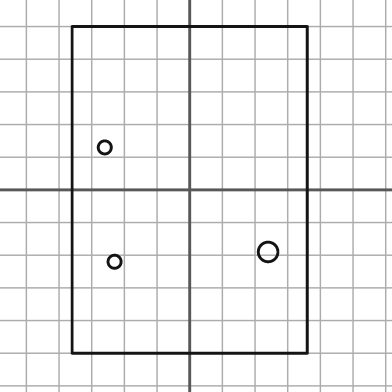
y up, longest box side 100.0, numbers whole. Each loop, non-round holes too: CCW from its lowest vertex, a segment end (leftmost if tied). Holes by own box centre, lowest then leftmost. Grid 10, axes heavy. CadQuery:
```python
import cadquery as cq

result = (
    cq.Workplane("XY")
    .moveTo(-36.0, -50.0)
    .lineTo(36.0, -50.0)
    .lineTo(36.0, 50.0)
    .lineTo(-36.0, 50.0)
    .close()
    .moveTo(-23.0, -22.0)
    .circle(2.0)
    .moveTo(24.0, -19.0)
    .circle(3.0)
    .moveTo(-26.0, 13.0)
    .circle(2.0)
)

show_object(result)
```